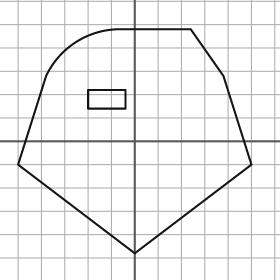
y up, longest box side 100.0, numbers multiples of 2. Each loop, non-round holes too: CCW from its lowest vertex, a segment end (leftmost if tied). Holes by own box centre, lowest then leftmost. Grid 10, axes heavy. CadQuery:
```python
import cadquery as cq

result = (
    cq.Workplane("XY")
    .moveTo(0.0, -48.0)
    .lineTo(50.0, -10.0)
    .lineTo(38.0, 28.0)
    .lineTo(24.0, 48.0)
    .lineTo(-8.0, 48.0)
    .threePointArc((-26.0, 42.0), (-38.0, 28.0))
    .lineTo(-50.0, -10.0)
    .close()
    .moveTo(-20.0, 14.0)
    .lineTo(-4.0, 14.0)
    .lineTo(-4.0, 22.0)
    .lineTo(-20.0, 22.0)
    .close()
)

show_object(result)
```